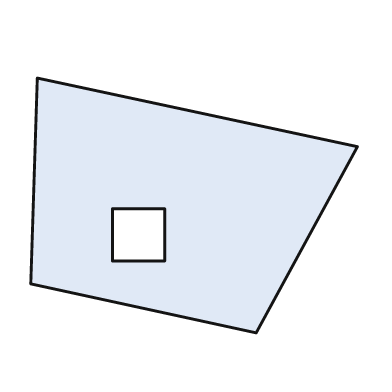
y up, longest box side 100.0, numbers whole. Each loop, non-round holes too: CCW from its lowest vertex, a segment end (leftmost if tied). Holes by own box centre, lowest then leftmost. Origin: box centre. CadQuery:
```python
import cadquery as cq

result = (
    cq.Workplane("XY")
    .moveTo(19.0, -39.0)
    .lineTo(50.0, 18.0)
    .lineTo(-48.0, 39.0)
    .lineTo(-50.0, -24.0)
    .close()
    .moveTo(-25.0, -17.0)
    .lineTo(-9.0, -17.0)
    .lineTo(-9.0, -1.0)
    .lineTo(-25.0, -1.0)
    .close()
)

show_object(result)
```